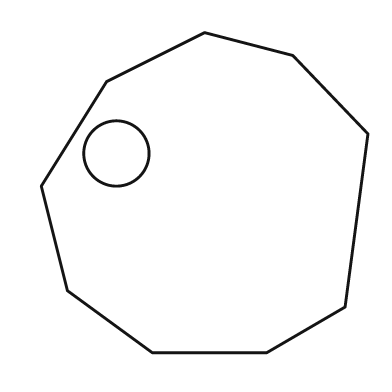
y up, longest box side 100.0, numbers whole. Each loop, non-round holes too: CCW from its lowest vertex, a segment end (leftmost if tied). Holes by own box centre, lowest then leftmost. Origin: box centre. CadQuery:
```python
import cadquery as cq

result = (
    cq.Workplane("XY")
    .moveTo(-16.0, -49.0)
    .lineTo(19.0, -49.0)
    .lineTo(43.0, -35.0)
    .lineTo(50.0, 18.0)
    .lineTo(27.0, 42.0)
    .lineTo(0.0, 49.0)
    .lineTo(-30.0, 34.0)
    .lineTo(-50.0, 2.0)
    .lineTo(-42.0, -30.0)
    .close()
    .moveTo(-27.0, 12.0)
    .circle(10.0)
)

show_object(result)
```